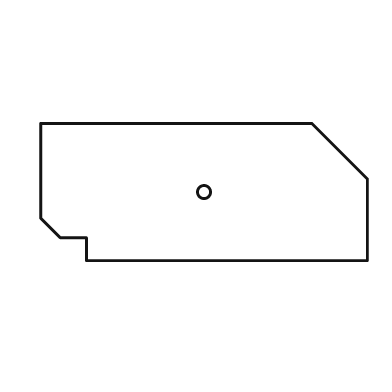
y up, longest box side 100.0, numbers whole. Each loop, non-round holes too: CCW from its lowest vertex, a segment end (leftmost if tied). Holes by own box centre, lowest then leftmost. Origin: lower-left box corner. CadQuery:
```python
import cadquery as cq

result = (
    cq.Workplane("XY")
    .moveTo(14.0, 0.0)
    .lineTo(100.0, 0.0)
    .lineTo(100.0, 25.0)
    .lineTo(83.0, 42.0)
    .lineTo(0.0, 42.0)
    .lineTo(0.0, 13.0)
    .lineTo(6.0, 7.0)
    .lineTo(14.0, 7.0)
    .close()
    .moveTo(50.0, 21.0)
    .circle(2.0)
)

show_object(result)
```